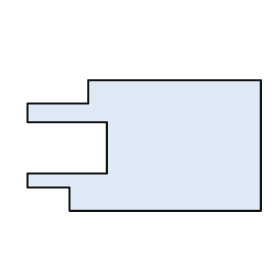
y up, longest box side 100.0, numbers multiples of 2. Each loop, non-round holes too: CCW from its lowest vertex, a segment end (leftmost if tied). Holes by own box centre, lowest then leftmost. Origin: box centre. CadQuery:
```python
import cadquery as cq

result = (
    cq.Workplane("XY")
    .moveTo(-32.0, -28.0)
    .lineTo(50.0, -28.0)
    .lineTo(50.0, 28.0)
    .lineTo(-24.0, 28.0)
    .lineTo(-24.0, 18.0)
    .lineTo(-50.0, 18.0)
    .lineTo(-50.0, 10.0)
    .lineTo(-16.0, 10.0)
    .lineTo(-16.0, -12.0)
    .lineTo(-50.0, -12.0)
    .lineTo(-50.0, -18.0)
    .lineTo(-32.0, -18.0)
    .close()
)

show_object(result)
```